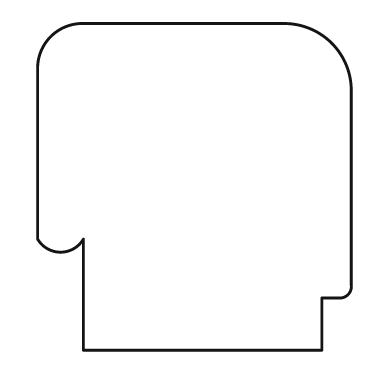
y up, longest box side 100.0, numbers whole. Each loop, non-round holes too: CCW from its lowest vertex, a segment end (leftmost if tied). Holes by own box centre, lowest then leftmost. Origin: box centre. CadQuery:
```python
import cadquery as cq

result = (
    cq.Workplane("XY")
    .moveTo(-34.0, -50.0)
    .lineTo(39.0, -50.0)
    .lineTo(39.0, -34.0)
    .lineTo(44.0, -34.0)
    .threePointArc((47.0, -33.0), (48.0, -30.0))
    .lineTo(48.0, 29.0)
    .threePointArc((42.0, 44.0), (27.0, 50.0))
    .lineTo(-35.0, 50.0)
    .threePointArc((-44.0, 46.0), (-48.0, 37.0))
    .lineTo(-48.0, -16.0)
    .threePointArc((-41.0, -20.0), (-34.0, -16.0))
    .close()
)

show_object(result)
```